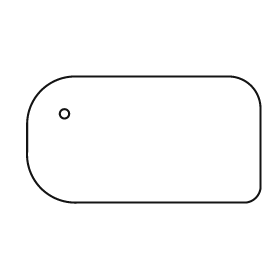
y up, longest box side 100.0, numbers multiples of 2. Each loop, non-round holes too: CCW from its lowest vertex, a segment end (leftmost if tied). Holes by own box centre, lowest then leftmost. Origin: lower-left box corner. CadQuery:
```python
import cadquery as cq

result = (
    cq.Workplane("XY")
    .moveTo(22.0, 0.0)
    .lineTo(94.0, 0.0)
    .threePointArc((98.0, 2.0), (100.0, 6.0))
    .lineTo(100.0, 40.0)
    .threePointArc((96.0, 50.0), (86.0, 54.0))
    .lineTo(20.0, 54.0)
    .threePointArc((6.0, 48.0), (0.0, 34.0))
    .lineTo(0.0, 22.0)
    .threePointArc((6.0, 6.0), (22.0, 0.0))
    .close()
    .moveTo(16.0, 38.0)
    .circle(2.0)
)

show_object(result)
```